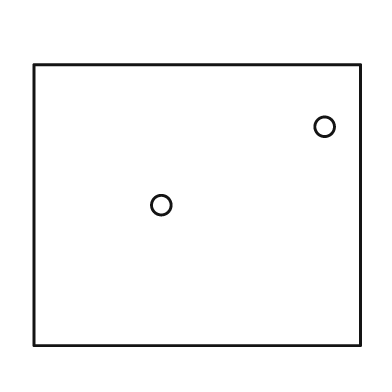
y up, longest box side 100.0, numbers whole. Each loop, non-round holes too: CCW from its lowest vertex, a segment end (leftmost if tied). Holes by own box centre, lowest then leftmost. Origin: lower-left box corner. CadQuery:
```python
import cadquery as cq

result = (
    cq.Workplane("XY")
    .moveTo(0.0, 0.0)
    .lineTo(100.0, 0.0)
    .lineTo(100.0, 86.0)
    .lineTo(0.0, 86.0)
    .close()
    .moveTo(39.0, 43.0)
    .circle(3.0)
    .moveTo(89.0, 67.0)
    .circle(3.0)
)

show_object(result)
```